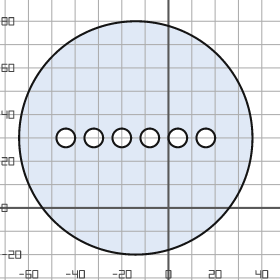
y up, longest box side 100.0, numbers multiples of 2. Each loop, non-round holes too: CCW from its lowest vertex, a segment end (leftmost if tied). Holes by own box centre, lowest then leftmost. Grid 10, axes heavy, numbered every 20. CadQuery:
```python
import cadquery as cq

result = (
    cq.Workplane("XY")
    .moveTo(-14.0, 30.0)
    .circle(50.0)
    .moveTo(-44.0, 30.0)
    .circle(4.0)
    .moveTo(-32.0, 30.0)
    .circle(4.0)
    .moveTo(-20.0, 30.0)
    .circle(4.0)
    .moveTo(-8.0, 30.0)
    .circle(4.0)
    .moveTo(4.0, 30.0)
    .circle(4.0)
    .moveTo(16.0, 30.0)
    .circle(4.0)
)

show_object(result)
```